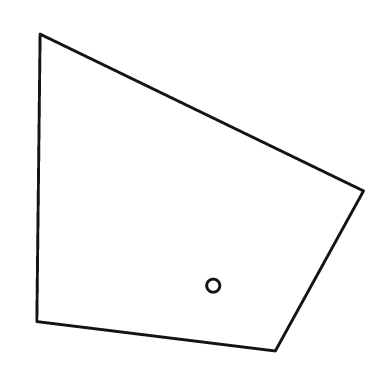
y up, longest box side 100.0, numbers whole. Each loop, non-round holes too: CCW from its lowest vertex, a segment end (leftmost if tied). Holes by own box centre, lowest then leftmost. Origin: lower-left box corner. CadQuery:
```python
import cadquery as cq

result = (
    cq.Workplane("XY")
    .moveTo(73.0, 0.0)
    .lineTo(100.0, 49.0)
    .lineTo(1.0, 97.0)
    .lineTo(0.0, 9.0)
    .close()
    .moveTo(54.0, 20.0)
    .circle(2.0)
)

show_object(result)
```